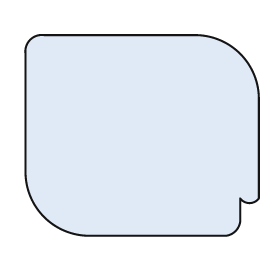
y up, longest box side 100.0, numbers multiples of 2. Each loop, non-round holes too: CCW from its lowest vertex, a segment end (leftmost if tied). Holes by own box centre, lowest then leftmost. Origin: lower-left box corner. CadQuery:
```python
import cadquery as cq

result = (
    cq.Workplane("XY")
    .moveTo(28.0, 0.0)
    .lineTo(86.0, 0.0)
    .threePointArc((90.0, 2.0), (92.0, 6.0))
    .lineTo(92.0, 16.0)
    .threePointArc((96.0, 14.0), (100.0, 16.0))
    .lineTo(100.0, 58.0)
    .threePointArc((92.0, 78.0), (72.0, 86.0))
    .lineTo(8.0, 86.0)
    .threePointArc((2.0, 84.0), (0.0, 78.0))
    .lineTo(0.0, 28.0)
    .threePointArc((8.0, 8.0), (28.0, 0.0))
    .close()
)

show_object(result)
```